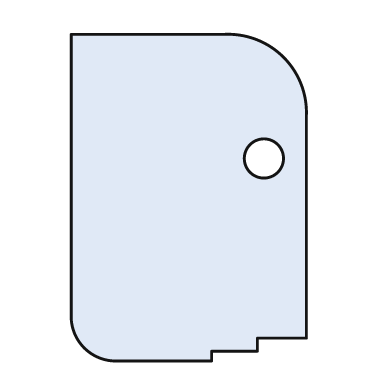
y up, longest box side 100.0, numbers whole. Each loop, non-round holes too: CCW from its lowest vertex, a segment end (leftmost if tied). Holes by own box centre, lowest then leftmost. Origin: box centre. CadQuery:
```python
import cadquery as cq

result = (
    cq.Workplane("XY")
    .moveTo(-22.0, -50.0)
    .lineTo(7.0, -50.0)
    .lineTo(7.0, -47.0)
    .lineTo(21.0, -47.0)
    .lineTo(21.0, -43.0)
    .lineTo(36.0, -43.0)
    .lineTo(36.0, 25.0)
    .threePointArc((29.0, 43.0), (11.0, 50.0))
    .lineTo(-36.0, 50.0)
    .lineTo(-36.0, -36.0)
    .threePointArc((-32.0, -46.0), (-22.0, -50.0))
    .close()
    .moveTo(23.0, 12.0)
    .circle(6.0)
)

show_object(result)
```